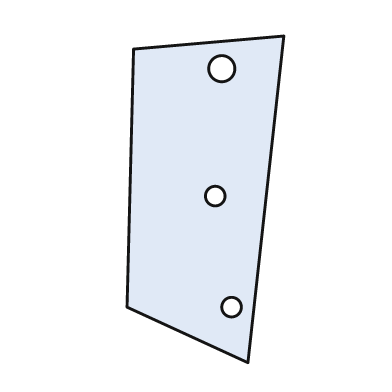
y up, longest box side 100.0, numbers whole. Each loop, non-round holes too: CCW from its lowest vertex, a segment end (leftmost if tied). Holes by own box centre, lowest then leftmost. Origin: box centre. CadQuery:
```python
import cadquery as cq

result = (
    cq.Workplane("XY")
    .moveTo(13.0, -50.0)
    .lineTo(24.0, 50.0)
    .lineTo(-22.0, 46.0)
    .lineTo(-24.0, -33.0)
    .close()
    .moveTo(8.0, -33.0)
    .circle(3.0)
    .moveTo(3.0, 1.0)
    .circle(3.0)
    .moveTo(5.0, 40.0)
    .circle(4.0)
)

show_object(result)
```